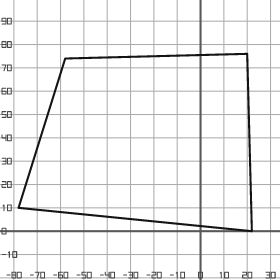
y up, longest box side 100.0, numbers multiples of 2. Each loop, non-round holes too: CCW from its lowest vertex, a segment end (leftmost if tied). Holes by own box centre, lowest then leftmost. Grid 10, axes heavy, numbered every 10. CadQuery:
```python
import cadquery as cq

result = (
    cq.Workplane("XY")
    .moveTo(22.0, 0.0)
    .lineTo(20.0, 76.0)
    .lineTo(-58.0, 74.0)
    .lineTo(-78.0, 10.0)
    .close()
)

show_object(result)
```